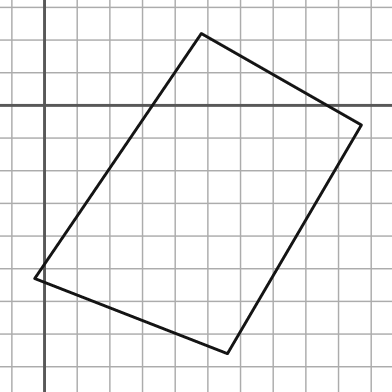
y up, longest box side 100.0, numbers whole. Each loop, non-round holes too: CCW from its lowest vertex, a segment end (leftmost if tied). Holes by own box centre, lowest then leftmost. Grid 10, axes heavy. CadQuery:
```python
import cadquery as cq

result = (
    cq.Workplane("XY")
    .moveTo(56.0, -76.0)
    .lineTo(97.0, -6.0)
    .lineTo(48.0, 22.0)
    .lineTo(-3.0, -53.0)
    .close()
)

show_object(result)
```